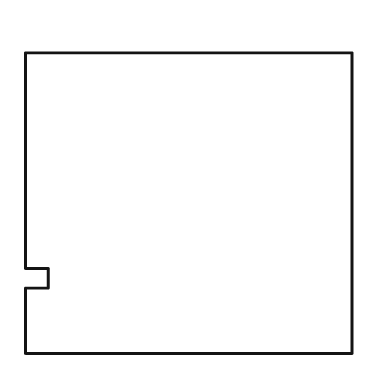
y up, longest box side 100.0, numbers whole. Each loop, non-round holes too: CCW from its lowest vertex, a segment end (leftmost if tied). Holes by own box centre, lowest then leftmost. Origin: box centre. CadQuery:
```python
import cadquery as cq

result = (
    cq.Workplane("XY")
    .moveTo(-50.0, -46.0)
    .lineTo(50.0, -46.0)
    .lineTo(50.0, 46.0)
    .lineTo(-50.0, 46.0)
    .lineTo(-50.0, -20.0)
    .lineTo(-43.0, -20.0)
    .lineTo(-43.0, -26.0)
    .lineTo(-50.0, -26.0)
    .close()
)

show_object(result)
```